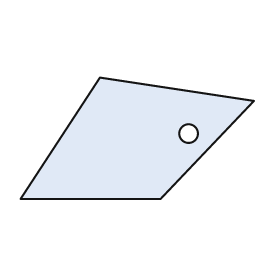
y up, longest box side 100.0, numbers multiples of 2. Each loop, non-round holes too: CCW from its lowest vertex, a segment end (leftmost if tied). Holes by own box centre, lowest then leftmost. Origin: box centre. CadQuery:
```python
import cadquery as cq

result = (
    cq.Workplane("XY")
    .moveTo(-50.0, -26.0)
    .lineTo(10.0, -26.0)
    .lineTo(50.0, 16.0)
    .lineTo(-16.0, 26.0)
    .close()
    .moveTo(22.0, 2.0)
    .circle(4.0)
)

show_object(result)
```